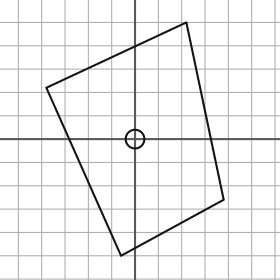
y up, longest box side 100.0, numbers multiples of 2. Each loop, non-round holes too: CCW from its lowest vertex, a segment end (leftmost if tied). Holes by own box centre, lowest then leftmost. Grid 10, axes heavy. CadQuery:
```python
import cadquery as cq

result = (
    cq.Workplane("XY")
    .moveTo(-6.0, -50.0)
    .lineTo(38.0, -26.0)
    .lineTo(22.0, 50.0)
    .lineTo(-38.0, 22.0)
    .close()
    .moveTo(0.0, 0.0)
    .circle(4.0)
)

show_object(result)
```